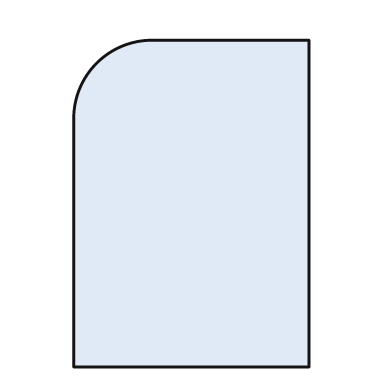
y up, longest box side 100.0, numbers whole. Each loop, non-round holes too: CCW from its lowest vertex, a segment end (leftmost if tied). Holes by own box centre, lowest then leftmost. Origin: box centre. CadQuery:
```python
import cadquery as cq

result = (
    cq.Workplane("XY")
    .moveTo(-36.0, -50.0)
    .lineTo(36.0, -50.0)
    .lineTo(36.0, 50.0)
    .lineTo(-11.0, 50.0)
    .threePointArc((-29.0, 43.0), (-36.0, 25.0))
    .close()
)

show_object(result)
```